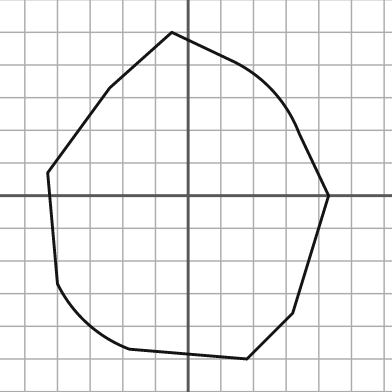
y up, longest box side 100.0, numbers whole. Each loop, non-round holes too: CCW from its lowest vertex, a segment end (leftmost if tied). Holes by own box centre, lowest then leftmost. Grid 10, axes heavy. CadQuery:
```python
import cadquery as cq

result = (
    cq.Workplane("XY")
    .moveTo(18.0, -50.0)
    .lineTo(32.0, -36.0)
    .lineTo(43.0, 0.0)
    .lineTo(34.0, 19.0)
    .threePointArc((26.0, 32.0), (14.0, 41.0))
    .lineTo(-5.0, 50.0)
    .lineTo(-24.0, 33.0)
    .lineTo(-43.0, 7.0)
    .lineTo(-40.0, -27.0)
    .threePointArc((-31.0, -39.0), (-18.0, -47.0))
    .close()
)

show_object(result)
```